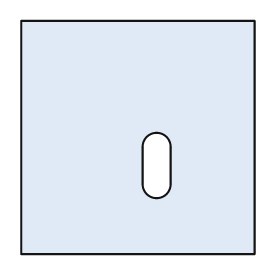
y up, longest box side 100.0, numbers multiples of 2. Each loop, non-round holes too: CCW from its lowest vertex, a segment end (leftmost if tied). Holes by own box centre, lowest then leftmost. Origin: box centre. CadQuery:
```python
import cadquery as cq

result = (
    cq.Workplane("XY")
    .moveTo(-50.0, -50.0)
    .lineTo(50.0, -50.0)
    .lineTo(50.0, 50.0)
    .lineTo(-50.0, 50.0)
    .close()
    .moveTo(2.0, -20.0)
    .threePointArc((8.0, -26.0), (14.0, -20.0))
    .lineTo(14.0, -4.0)
    .threePointArc((8.0, 2.0), (2.0, -4.0))
    .close()
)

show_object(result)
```